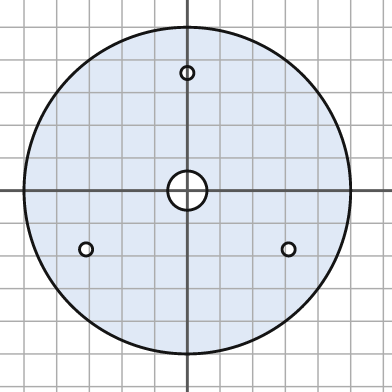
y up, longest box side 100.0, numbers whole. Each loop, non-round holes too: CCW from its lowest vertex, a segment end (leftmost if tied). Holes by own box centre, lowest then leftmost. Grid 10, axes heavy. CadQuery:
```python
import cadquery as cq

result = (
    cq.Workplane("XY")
    .moveTo(0.0, 0.0)
    .circle(50.0)
    .moveTo(-31.0, -18.0)
    .circle(2.0)
    .moveTo(31.0, -18.0)
    .circle(2.0)
    .moveTo(0.0, 0.0)
    .circle(6.0)
    .moveTo(0.0, 36.0)
    .circle(2.0)
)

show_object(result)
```